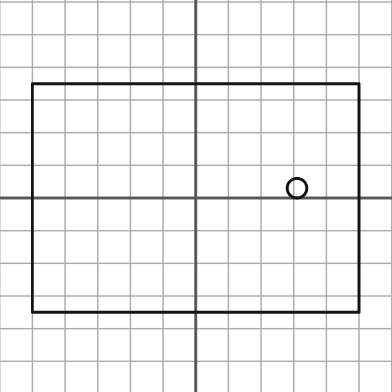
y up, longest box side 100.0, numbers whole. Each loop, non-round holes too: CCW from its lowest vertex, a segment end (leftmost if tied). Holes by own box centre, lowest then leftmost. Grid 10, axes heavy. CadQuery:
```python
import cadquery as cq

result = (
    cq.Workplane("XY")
    .moveTo(-50.0, -35.0)
    .lineTo(50.0, -35.0)
    .lineTo(50.0, 35.0)
    .lineTo(-50.0, 35.0)
    .close()
    .moveTo(31.0, 3.0)
    .circle(3.0)
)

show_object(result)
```